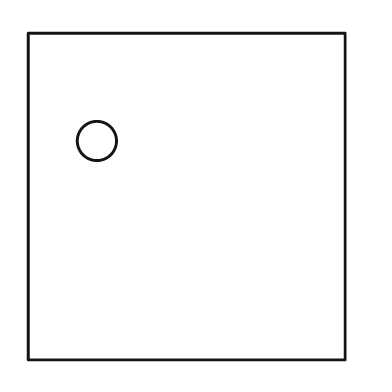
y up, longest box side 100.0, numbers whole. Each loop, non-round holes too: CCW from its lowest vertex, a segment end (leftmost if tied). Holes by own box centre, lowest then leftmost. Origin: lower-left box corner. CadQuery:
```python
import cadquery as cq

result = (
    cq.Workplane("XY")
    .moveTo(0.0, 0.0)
    .lineTo(97.0, 0.0)
    .lineTo(97.0, 100.0)
    .lineTo(0.0, 100.0)
    .close()
    .moveTo(21.0, 67.0)
    .circle(6.0)
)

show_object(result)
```